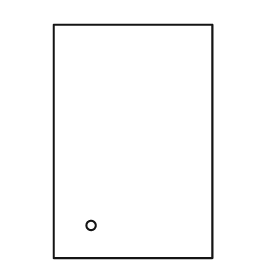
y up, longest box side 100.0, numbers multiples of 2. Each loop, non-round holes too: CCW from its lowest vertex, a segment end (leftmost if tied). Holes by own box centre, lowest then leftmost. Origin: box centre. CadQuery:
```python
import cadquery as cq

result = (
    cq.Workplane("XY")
    .moveTo(-34.0, -50.0)
    .lineTo(34.0, -50.0)
    .lineTo(34.0, 50.0)
    .lineTo(-34.0, 50.0)
    .close()
    .moveTo(-18.0, -36.0)
    .circle(2.0)
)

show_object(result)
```